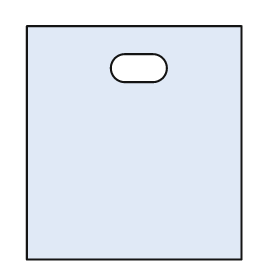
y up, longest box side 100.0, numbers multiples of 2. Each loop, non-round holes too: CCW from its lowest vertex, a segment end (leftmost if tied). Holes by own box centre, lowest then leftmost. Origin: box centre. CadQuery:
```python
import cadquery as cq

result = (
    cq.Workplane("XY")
    .moveTo(-46.0, -50.0)
    .lineTo(46.0, -50.0)
    .lineTo(46.0, 50.0)
    .lineTo(-46.0, 50.0)
    .close()
    .moveTo(-4.0, 26.0)
    .lineTo(8.0, 26.0)
    .threePointArc((14.0, 32.0), (8.0, 38.0))
    .lineTo(-4.0, 38.0)
    .threePointArc((-10.0, 32.0), (-4.0, 26.0))
    .close()
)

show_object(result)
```